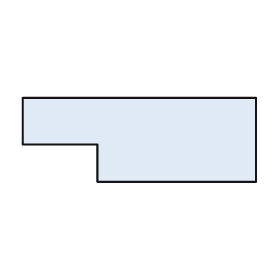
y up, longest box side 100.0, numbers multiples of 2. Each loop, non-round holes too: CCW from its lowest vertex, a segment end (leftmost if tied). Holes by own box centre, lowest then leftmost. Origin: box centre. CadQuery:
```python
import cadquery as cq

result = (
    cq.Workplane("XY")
    .moveTo(-18.0, -18.0)
    .lineTo(50.0, -18.0)
    .lineTo(50.0, 18.0)
    .lineTo(-50.0, 18.0)
    .lineTo(-50.0, -2.0)
    .lineTo(-18.0, -2.0)
    .close()
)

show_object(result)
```